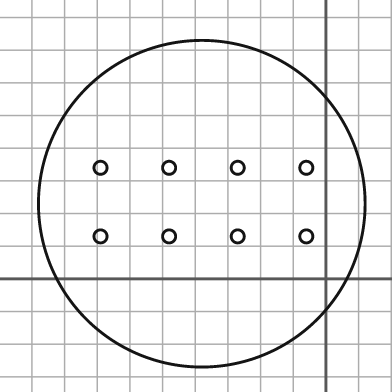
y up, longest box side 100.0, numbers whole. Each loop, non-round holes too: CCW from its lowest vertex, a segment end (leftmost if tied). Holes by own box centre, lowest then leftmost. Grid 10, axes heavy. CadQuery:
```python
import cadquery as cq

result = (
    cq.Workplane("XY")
    .moveTo(-38.0, 23.0)
    .circle(50.0)
    .moveTo(-69.0, 13.0)
    .circle(2.0)
    .moveTo(-48.0, 13.0)
    .circle(2.0)
    .moveTo(-27.0, 13.0)
    .circle(2.0)
    .moveTo(-6.0, 13.0)
    .circle(2.0)
    .moveTo(-69.0, 34.0)
    .circle(2.0)
    .moveTo(-48.0, 34.0)
    .circle(2.0)
    .moveTo(-27.0, 34.0)
    .circle(2.0)
    .moveTo(-6.0, 34.0)
    .circle(2.0)
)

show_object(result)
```